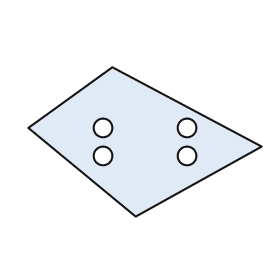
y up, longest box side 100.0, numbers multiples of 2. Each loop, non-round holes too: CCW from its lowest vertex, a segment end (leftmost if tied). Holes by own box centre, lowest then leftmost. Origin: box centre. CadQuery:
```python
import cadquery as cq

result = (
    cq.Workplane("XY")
    .moveTo(-4.0, -32.0)
    .lineTo(50.0, -2.0)
    .lineTo(-14.0, 32.0)
    .lineTo(-50.0, 6.0)
    .close()
    .moveTo(-18.0, -6.0)
    .circle(4.0)
    .moveTo(18.0, -6.0)
    .circle(4.0)
    .moveTo(-18.0, 6.0)
    .circle(4.0)
    .moveTo(18.0, 6.0)
    .circle(4.0)
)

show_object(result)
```